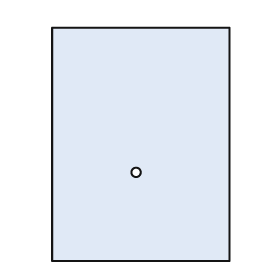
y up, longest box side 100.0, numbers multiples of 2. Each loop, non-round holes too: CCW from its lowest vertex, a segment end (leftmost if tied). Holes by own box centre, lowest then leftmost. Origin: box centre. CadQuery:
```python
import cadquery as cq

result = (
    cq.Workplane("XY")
    .moveTo(-38.0, -50.0)
    .lineTo(38.0, -50.0)
    .lineTo(38.0, 50.0)
    .lineTo(-38.0, 50.0)
    .close()
    .moveTo(-2.0, -12.0)
    .circle(2.0)
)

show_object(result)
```